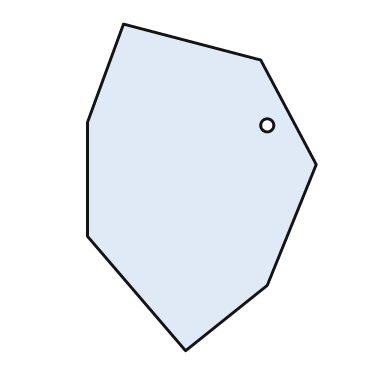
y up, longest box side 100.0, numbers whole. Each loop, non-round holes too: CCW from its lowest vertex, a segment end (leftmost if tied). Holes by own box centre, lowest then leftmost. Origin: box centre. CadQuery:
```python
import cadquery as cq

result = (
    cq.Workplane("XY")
    .moveTo(-5.0, -50.0)
    .lineTo(20.0, -30.0)
    .lineTo(35.0, 7.0)
    .lineTo(18.0, 39.0)
    .lineTo(-24.0, 50.0)
    .lineTo(-35.0, 20.0)
    .lineTo(-35.0, -15.0)
    .close()
    .moveTo(20.0, 19.0)
    .circle(2.0)
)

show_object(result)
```